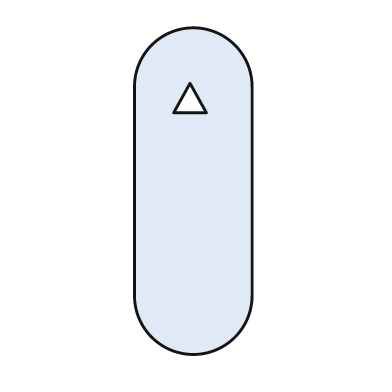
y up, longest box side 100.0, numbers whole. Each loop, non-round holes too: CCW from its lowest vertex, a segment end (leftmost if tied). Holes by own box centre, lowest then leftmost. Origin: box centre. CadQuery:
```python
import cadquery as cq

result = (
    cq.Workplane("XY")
    .moveTo(-18.0, -32.0)
    .threePointArc((0.0, -50.0), (18.0, -32.0))
    .lineTo(18.0, 32.0)
    .threePointArc((0.0, 50.0), (-18.0, 32.0))
    .close()
    .moveTo(-6.0, 24.0)
    .lineTo(4.0, 24.0)
    .lineTo(-1.0, 33.0)
    .close()
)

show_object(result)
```